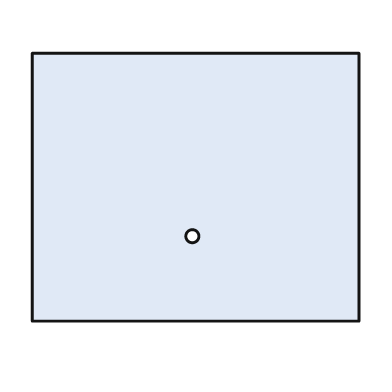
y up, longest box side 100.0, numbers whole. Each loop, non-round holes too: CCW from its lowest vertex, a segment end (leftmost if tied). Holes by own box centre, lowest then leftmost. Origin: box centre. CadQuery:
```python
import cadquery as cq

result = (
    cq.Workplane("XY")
    .moveTo(-50.0, -41.0)
    .lineTo(50.0, -41.0)
    .lineTo(50.0, 41.0)
    .lineTo(-50.0, 41.0)
    .close()
    .moveTo(-1.0, -15.0)
    .circle(2.0)
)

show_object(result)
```